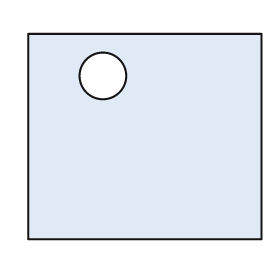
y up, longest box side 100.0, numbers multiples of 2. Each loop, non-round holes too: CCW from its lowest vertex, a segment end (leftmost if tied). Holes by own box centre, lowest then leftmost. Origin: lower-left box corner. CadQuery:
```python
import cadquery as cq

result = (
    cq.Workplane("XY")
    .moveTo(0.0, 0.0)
    .lineTo(100.0, 0.0)
    .lineTo(100.0, 88.0)
    .lineTo(0.0, 88.0)
    .close()
    .moveTo(32.0, 70.0)
    .circle(10.0)
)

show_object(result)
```